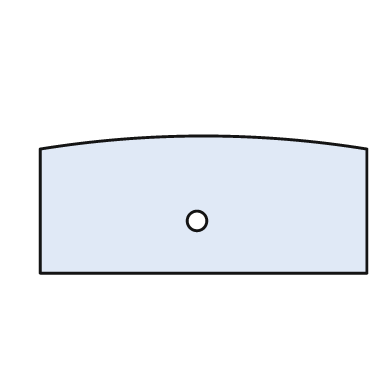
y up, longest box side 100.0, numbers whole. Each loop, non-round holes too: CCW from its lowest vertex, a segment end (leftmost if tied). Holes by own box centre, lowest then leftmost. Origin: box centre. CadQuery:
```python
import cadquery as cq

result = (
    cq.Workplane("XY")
    .moveTo(-50.0, -21.0)
    .lineTo(50.0, -21.0)
    .lineTo(50.0, 17.0)
    .threePointArc((0.0, 21.0), (-50.0, 17.0))
    .close()
    .moveTo(-2.0, -5.0)
    .circle(3.0)
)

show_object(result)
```